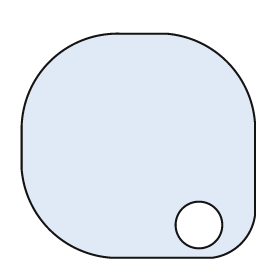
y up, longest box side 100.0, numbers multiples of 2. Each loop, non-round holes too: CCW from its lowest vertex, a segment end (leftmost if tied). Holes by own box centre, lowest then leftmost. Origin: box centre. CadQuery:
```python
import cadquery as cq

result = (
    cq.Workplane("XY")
    .moveTo(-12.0, -48.0)
    .lineTo(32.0, -48.0)
    .threePointArc((44.0, -42.0), (50.0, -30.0))
    .lineTo(50.0, 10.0)
    .threePointArc((38.0, 36.0), (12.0, 48.0))
    .lineTo(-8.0, 48.0)
    .threePointArc((-38.0, 36.0), (-50.0, 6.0))
    .lineTo(-50.0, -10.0)
    .threePointArc((-38.0, -36.0), (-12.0, -48.0))
    .close()
    .moveTo(26.0, -34.0)
    .circle(10.0)
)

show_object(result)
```